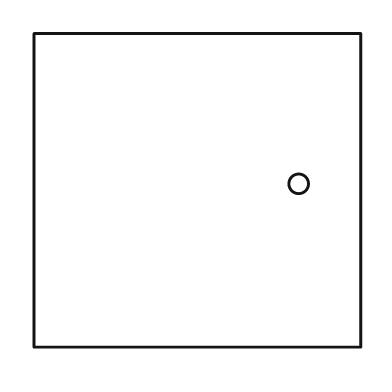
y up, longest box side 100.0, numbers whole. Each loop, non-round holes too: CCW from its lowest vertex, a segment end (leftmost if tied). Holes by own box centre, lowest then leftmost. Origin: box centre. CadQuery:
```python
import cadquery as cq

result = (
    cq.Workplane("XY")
    .moveTo(-50.0, -48.0)
    .lineTo(50.0, -48.0)
    .lineTo(50.0, 48.0)
    .lineTo(-50.0, 48.0)
    .close()
    .moveTo(31.0, 2.0)
    .circle(3.0)
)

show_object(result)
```